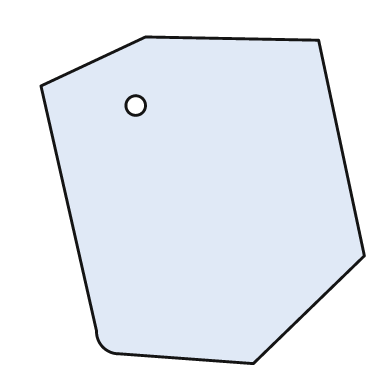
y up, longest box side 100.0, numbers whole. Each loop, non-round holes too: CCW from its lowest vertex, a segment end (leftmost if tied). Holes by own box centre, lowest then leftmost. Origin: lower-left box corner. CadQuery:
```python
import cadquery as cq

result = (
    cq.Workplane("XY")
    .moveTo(65.0, 0.0)
    .lineTo(99.0, 33.0)
    .lineTo(85.0, 99.0)
    .lineTo(32.0, 100.0)
    .lineTo(0.0, 85.0)
    .lineTo(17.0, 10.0)
    .threePointArc((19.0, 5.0), (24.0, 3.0))
    .close()
    .moveTo(29.0, 79.0)
    .circle(3.0)
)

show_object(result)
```